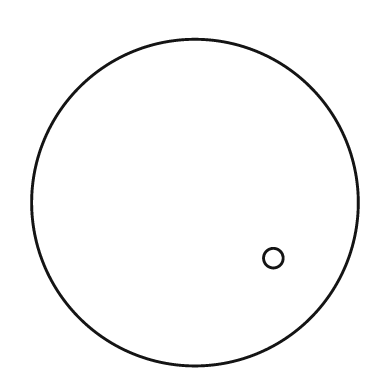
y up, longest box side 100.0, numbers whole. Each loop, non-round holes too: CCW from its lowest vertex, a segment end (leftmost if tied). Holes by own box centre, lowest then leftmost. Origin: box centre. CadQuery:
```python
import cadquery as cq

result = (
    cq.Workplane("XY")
    .moveTo(0.0, 0.0)
    .circle(50.0)
    .moveTo(24.0, -17.0)
    .circle(3.0)
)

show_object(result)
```